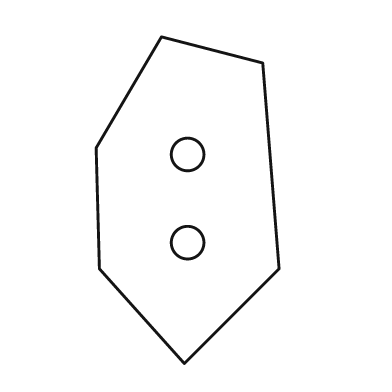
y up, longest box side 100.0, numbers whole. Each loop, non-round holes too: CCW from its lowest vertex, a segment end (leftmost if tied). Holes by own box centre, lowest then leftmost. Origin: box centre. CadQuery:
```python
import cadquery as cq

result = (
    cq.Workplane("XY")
    .moveTo(-1.0, -50.0)
    .lineTo(28.0, -21.0)
    .lineTo(23.0, 42.0)
    .lineTo(-8.0, 50.0)
    .lineTo(-28.0, 16.0)
    .lineTo(-27.0, -21.0)
    .close()
    .moveTo(0.0, -13.0)
    .circle(5.0)
    .moveTo(0.0, 14.0)
    .circle(5.0)
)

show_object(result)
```